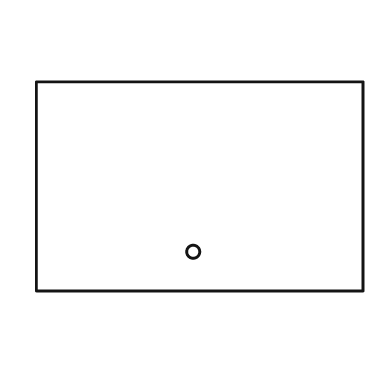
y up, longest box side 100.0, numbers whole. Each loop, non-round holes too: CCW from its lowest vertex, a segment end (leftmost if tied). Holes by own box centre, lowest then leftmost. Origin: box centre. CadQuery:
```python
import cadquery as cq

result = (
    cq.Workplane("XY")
    .moveTo(-50.0, -32.0)
    .lineTo(50.0, -32.0)
    .lineTo(50.0, 32.0)
    .lineTo(-50.0, 32.0)
    .close()
    .moveTo(-2.0, -20.0)
    .circle(2.0)
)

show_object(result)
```